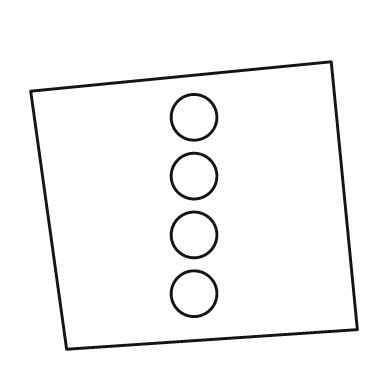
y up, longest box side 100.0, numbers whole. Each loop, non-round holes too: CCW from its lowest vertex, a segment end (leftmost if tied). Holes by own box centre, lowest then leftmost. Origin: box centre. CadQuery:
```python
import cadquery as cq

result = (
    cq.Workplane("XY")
    .moveTo(-39.0, -44.0)
    .lineTo(50.0, -38.0)
    .lineTo(42.0, 44.0)
    .lineTo(-50.0, 35.0)
    .close()
    .moveTo(0.0, -27.0)
    .circle(7.0)
    .moveTo(0.0, -9.0)
    .circle(7.0)
    .moveTo(0.0, 9.0)
    .circle(7.0)
    .moveTo(0.0, 27.0)
    .circle(7.0)
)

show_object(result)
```